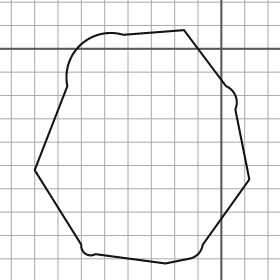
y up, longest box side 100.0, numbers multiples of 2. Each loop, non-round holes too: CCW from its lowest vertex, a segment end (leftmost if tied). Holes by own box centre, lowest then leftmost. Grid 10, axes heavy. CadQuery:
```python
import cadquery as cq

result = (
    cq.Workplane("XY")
    .moveTo(-24.0, -92.0)
    .lineTo(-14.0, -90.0)
    .threePointArc((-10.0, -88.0), (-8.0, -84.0))
    .lineTo(12.0, -56.0)
    .lineTo(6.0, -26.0)
    .threePointArc((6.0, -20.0), (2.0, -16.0))
    .lineTo(-16.0, 8.0)
    .lineTo(-42.0, 6.0)
    .threePointArc((-60.0, 2.0), (-66.0, -16.0))
    .lineTo(-80.0, -52.0)
    .lineTo(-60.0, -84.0)
    .threePointArc((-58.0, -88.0), (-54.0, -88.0))
    .close()
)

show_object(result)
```